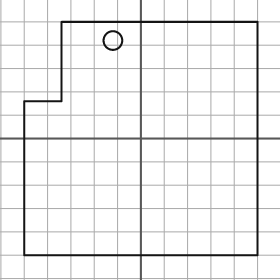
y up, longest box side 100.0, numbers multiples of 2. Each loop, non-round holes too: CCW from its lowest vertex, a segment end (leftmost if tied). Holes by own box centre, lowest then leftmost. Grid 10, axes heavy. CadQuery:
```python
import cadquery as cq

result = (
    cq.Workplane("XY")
    .moveTo(-50.0, -50.0)
    .lineTo(50.0, -50.0)
    .lineTo(50.0, 50.0)
    .lineTo(-34.0, 50.0)
    .lineTo(-34.0, 16.0)
    .lineTo(-50.0, 16.0)
    .close()
    .moveTo(-12.0, 42.0)
    .circle(4.0)
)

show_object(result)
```